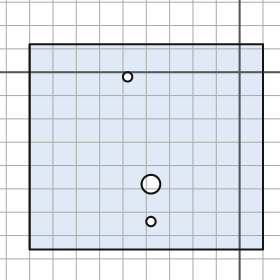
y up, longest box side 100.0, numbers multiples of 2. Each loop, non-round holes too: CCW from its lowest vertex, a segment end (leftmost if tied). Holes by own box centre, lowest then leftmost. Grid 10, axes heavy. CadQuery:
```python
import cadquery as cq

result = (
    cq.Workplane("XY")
    .moveTo(-90.0, -76.0)
    .lineTo(10.0, -76.0)
    .lineTo(10.0, 12.0)
    .lineTo(-90.0, 12.0)
    .close()
    .moveTo(-38.0, -64.0)
    .circle(2.0)
    .moveTo(-38.0, -48.0)
    .circle(4.0)
    .moveTo(-48.0, -2.0)
    .circle(2.0)
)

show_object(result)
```